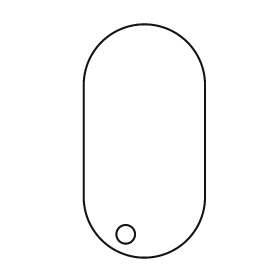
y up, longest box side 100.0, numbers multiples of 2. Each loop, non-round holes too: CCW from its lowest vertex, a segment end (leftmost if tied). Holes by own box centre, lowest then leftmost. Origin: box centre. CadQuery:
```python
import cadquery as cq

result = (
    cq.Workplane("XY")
    .moveTo(-26.0, -24.0)
    .threePointArc((0.0, -50.0), (26.0, -24.0))
    .lineTo(26.0, 24.0)
    .threePointArc((0.0, 50.0), (-26.0, 24.0))
    .close()
    .moveTo(-8.0, -40.0)
    .circle(4.0)
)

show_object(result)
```